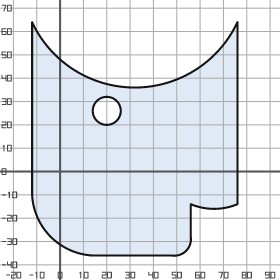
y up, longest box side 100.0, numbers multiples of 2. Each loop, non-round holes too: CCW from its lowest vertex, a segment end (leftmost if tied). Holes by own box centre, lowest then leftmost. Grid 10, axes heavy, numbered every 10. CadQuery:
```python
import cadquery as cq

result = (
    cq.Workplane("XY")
    .moveTo(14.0, -36.0)
    .lineTo(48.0, -36.0)
    .threePointArc((54.0, -34.0), (56.0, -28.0))
    .lineTo(56.0, -14.0)
    .threePointArc((66.0, -16.0), (76.0, -14.0))
    .lineTo(76.0, 64.0)
    .threePointArc((32.0, 36.0), (-12.0, 64.0))
    .lineTo(-12.0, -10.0)
    .threePointArc((-4.0, -28.0), (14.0, -36.0))
    .close()
    .moveTo(20.0, 26.0)
    .circle(6.0)
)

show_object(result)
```